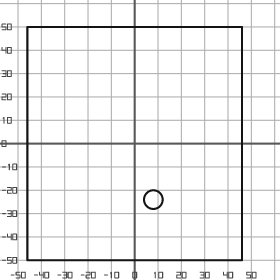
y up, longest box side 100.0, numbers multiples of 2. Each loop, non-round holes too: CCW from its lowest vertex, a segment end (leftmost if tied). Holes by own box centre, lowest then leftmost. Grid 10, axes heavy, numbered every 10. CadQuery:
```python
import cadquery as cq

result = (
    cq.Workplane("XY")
    .moveTo(-46.0, -50.0)
    .lineTo(46.0, -50.0)
    .lineTo(46.0, 50.0)
    .lineTo(-46.0, 50.0)
    .close()
    .moveTo(8.0, -24.0)
    .circle(4.0)
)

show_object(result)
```